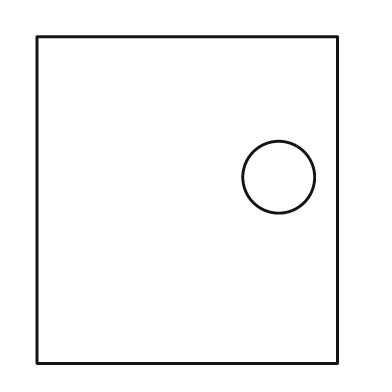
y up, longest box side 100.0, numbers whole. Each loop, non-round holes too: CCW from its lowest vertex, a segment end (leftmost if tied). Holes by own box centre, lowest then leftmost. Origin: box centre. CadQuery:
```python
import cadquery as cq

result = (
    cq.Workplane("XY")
    .moveTo(-46.0, -50.0)
    .lineTo(46.0, -50.0)
    .lineTo(46.0, 50.0)
    .lineTo(-46.0, 50.0)
    .close()
    .moveTo(28.0, 7.0)
    .circle(11.0)
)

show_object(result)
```